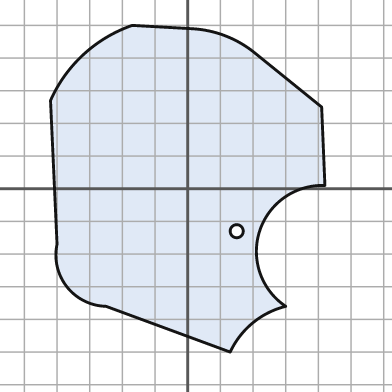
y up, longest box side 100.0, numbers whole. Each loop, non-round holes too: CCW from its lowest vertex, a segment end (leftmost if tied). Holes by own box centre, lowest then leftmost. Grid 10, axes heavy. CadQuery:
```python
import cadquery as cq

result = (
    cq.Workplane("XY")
    .moveTo(13.0, -50.0)
    .threePointArc((20.0, -41.0), (30.0, -36.0))
    .threePointArc((22.0, -13.0), (42.0, 1.0))
    .lineTo(41.0, 25.0)
    .lineTo(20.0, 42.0)
    .threePointArc((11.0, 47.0), (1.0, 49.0))
    .lineTo(-17.0, 50.0)
    .threePointArc((-32.0, 41.0), (-42.0, 27.0))
    .lineTo(-40.0, -17.0)
    .threePointArc((-37.0, -30.0), (-25.0, -36.0))
    .close()
    .moveTo(15.0, -13.0)
    .circle(2.0)
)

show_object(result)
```